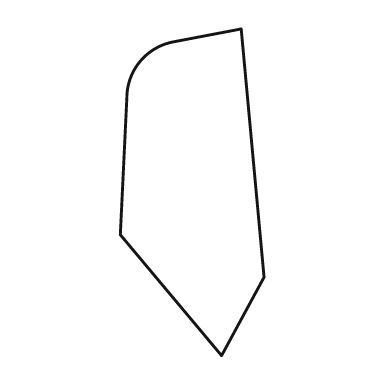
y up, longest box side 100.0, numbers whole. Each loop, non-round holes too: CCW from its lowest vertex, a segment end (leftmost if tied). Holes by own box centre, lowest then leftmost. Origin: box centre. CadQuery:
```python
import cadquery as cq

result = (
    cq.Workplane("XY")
    .moveTo(9.0, -50.0)
    .lineTo(22.0, -26.0)
    .lineTo(15.0, 50.0)
    .lineTo(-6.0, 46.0)
    .threePointArc((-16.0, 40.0), (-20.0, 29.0))
    .lineTo(-22.0, -13.0)
    .close()
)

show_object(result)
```